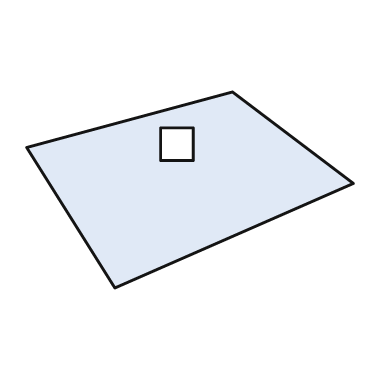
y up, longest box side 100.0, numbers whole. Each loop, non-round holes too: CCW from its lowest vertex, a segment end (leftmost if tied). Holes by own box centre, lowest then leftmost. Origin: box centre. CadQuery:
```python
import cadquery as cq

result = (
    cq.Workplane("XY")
    .moveTo(-23.0, -30.0)
    .lineTo(50.0, 2.0)
    .lineTo(13.0, 30.0)
    .lineTo(-50.0, 13.0)
    .close()
    .moveTo(-9.0, 9.0)
    .lineTo(1.0, 9.0)
    .lineTo(1.0, 19.0)
    .lineTo(-9.0, 19.0)
    .close()
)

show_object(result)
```